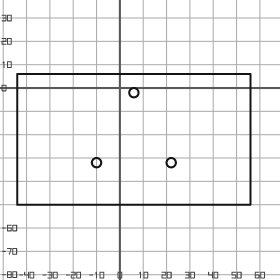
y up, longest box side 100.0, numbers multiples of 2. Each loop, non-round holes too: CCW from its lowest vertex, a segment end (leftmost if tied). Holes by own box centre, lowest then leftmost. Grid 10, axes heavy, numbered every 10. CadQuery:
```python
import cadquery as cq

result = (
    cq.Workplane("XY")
    .moveTo(-44.0, -50.0)
    .lineTo(56.0, -50.0)
    .lineTo(56.0, 6.0)
    .lineTo(-44.0, 6.0)
    .close()
    .moveTo(-10.0, -32.0)
    .circle(2.0)
    .moveTo(22.0, -32.0)
    .circle(2.0)
    .moveTo(6.0, -2.0)
    .circle(2.0)
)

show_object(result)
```